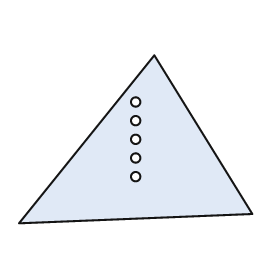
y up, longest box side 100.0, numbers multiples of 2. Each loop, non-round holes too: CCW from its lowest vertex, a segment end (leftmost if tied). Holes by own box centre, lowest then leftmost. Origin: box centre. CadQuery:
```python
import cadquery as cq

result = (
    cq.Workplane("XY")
    .moveTo(-50.0, -36.0)
    .lineTo(50.0, -32.0)
    .lineTo(8.0, 36.0)
    .close()
    .moveTo(0.0, -16.0)
    .circle(2.0)
    .moveTo(0.0, -8.0)
    .circle(2.0)
    .moveTo(0.0, 0.0)
    .circle(2.0)
    .moveTo(0.0, 8.0)
    .circle(2.0)
    .moveTo(0.0, 16.0)
    .circle(2.0)
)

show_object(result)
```